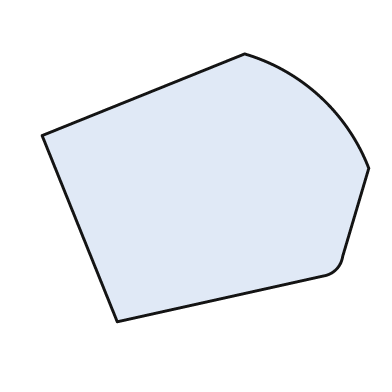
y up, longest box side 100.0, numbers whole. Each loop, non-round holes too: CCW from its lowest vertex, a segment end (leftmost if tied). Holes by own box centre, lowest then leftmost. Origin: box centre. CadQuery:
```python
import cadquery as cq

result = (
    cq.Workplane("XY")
    .moveTo(-27.0, -41.0)
    .lineTo(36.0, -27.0)
    .threePointArc((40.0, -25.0), (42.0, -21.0))
    .lineTo(50.0, 6.0)
    .threePointArc((35.0, 28.0), (12.0, 41.0))
    .lineTo(-50.0, 16.0)
    .close()
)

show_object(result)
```